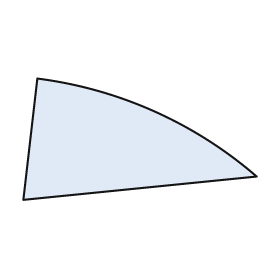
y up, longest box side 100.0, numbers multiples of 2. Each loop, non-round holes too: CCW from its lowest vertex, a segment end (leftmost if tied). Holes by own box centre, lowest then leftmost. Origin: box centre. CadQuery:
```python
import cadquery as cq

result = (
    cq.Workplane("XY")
    .moveTo(-50.0, -26.0)
    .lineTo(50.0, -16.0)
    .threePointArc((6.0, 12.0), (-44.0, 26.0))
    .close()
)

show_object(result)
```